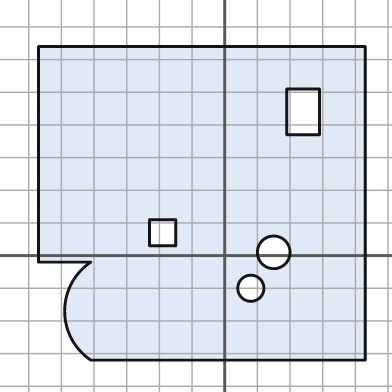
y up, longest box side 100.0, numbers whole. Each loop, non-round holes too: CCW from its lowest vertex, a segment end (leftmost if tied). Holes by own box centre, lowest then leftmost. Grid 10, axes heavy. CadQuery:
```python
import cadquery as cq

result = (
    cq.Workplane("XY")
    .moveTo(-41.0, -32.0)
    .lineTo(43.0, -32.0)
    .lineTo(43.0, 64.0)
    .lineTo(-57.0, 64.0)
    .lineTo(-57.0, -2.0)
    .lineTo(-41.0, -2.0)
    .threePointArc((-49.0, -17.0), (-41.0, -32.0))
    .close()
    .moveTo(8.0, -10.0)
    .circle(4.0)
    .moveTo(15.0, 1.0)
    .circle(5.0)
    .moveTo(-23.0, 3.0)
    .lineTo(-15.0, 3.0)
    .lineTo(-15.0, 11.0)
    .lineTo(-23.0, 11.0)
    .close()
    .moveTo(19.0, 37.0)
    .lineTo(29.0, 37.0)
    .lineTo(29.0, 51.0)
    .lineTo(19.0, 51.0)
    .close()
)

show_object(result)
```